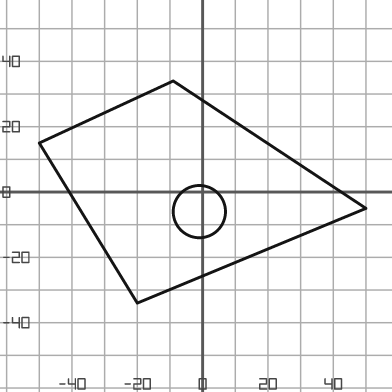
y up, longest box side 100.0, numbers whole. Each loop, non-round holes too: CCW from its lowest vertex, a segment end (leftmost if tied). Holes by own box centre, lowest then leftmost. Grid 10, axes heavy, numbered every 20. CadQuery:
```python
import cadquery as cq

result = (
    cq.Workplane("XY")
    .moveTo(-20.0, -34.0)
    .lineTo(50.0, -5.0)
    .lineTo(-9.0, 34.0)
    .lineTo(-50.0, 15.0)
    .close()
    .moveTo(-1.0, -6.0)
    .circle(8.0)
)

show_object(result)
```